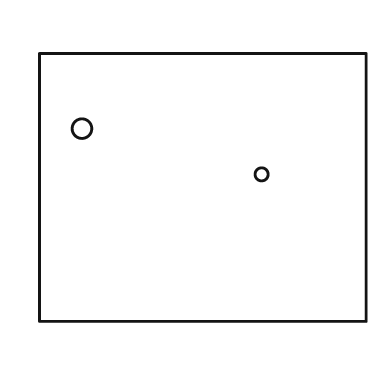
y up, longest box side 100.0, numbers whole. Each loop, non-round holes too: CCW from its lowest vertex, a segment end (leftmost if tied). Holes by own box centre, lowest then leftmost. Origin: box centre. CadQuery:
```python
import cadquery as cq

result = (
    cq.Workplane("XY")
    .moveTo(-50.0, -41.0)
    .lineTo(50.0, -41.0)
    .lineTo(50.0, 41.0)
    .lineTo(-50.0, 41.0)
    .close()
    .moveTo(18.0, 4.0)
    .circle(2.0)
    .moveTo(-37.0, 18.0)
    .circle(3.0)
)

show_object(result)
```